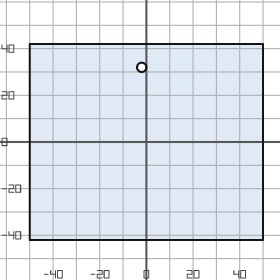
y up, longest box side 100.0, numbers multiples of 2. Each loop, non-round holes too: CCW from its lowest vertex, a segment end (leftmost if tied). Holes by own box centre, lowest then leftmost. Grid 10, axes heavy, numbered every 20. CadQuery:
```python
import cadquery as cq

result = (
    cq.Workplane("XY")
    .moveTo(-50.0, -42.0)
    .lineTo(50.0, -42.0)
    .lineTo(50.0, 42.0)
    .lineTo(-50.0, 42.0)
    .close()
    .moveTo(-2.0, 32.0)
    .circle(2.0)
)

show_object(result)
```